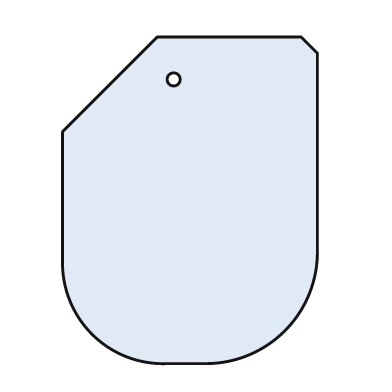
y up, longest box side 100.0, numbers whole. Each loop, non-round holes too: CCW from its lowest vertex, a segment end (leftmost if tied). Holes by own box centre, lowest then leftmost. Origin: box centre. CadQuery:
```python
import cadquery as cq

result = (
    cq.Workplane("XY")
    .moveTo(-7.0, -50.0)
    .lineTo(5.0, -50.0)
    .threePointArc((29.0, -40.0), (39.0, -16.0))
    .lineTo(39.0, 45.0)
    .lineTo(34.0, 50.0)
    .lineTo(-10.0, 50.0)
    .lineTo(-39.0, 21.0)
    .lineTo(-39.0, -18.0)
    .threePointArc((-30.0, -41.0), (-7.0, -50.0))
    .close()
    .moveTo(-5.0, 37.0)
    .circle(2.0)
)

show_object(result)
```